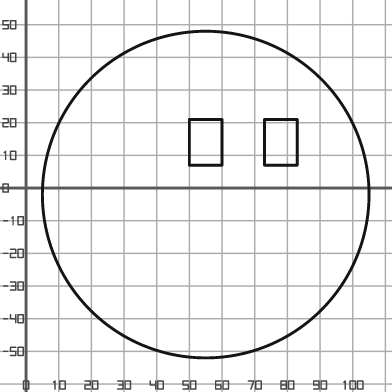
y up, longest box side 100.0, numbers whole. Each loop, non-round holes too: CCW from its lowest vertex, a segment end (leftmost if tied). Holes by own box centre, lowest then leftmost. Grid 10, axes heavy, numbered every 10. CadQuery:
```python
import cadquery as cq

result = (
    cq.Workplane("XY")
    .moveTo(55.0, -2.0)
    .circle(50.0)
    .moveTo(50.0, 7.0)
    .lineTo(60.0, 7.0)
    .lineTo(60.0, 21.0)
    .lineTo(50.0, 21.0)
    .close()
    .moveTo(73.0, 7.0)
    .lineTo(83.0, 7.0)
    .lineTo(83.0, 21.0)
    .lineTo(73.0, 21.0)
    .close()
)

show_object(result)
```